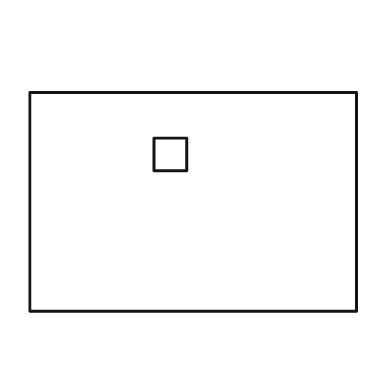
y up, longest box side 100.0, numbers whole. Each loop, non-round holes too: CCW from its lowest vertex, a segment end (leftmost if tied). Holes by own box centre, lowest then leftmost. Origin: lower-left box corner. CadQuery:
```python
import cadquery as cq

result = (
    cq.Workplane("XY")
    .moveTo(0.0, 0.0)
    .lineTo(100.0, 0.0)
    .lineTo(100.0, 67.0)
    .lineTo(0.0, 67.0)
    .close()
    .moveTo(38.0, 43.0)
    .lineTo(48.0, 43.0)
    .lineTo(48.0, 53.0)
    .lineTo(38.0, 53.0)
    .close()
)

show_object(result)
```